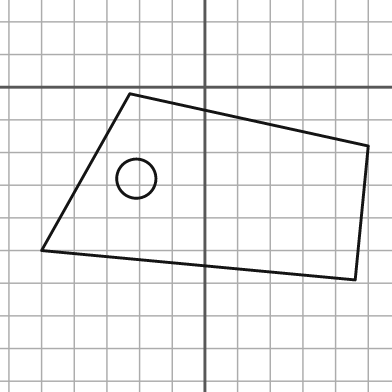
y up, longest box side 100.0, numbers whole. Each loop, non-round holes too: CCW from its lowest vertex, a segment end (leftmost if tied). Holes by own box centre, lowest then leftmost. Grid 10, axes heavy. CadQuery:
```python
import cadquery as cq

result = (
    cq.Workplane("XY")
    .moveTo(46.0, -59.0)
    .lineTo(50.0, -18.0)
    .lineTo(-23.0, -2.0)
    .lineTo(-50.0, -50.0)
    .close()
    .moveTo(-21.0, -28.0)
    .circle(6.0)
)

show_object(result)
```